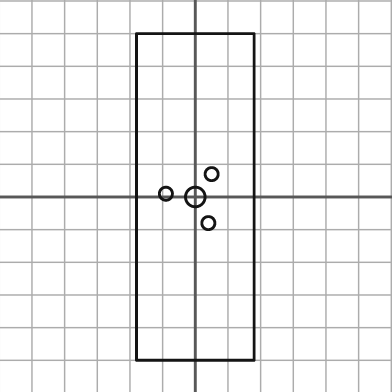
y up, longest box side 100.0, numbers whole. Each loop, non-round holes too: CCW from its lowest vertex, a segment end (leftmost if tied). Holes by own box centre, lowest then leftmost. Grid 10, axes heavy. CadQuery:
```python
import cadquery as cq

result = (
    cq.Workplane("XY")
    .moveTo(-18.0, -50.0)
    .lineTo(18.0, -50.0)
    .lineTo(18.0, 50.0)
    .lineTo(-18.0, 50.0)
    .close()
    .moveTo(4.0, -8.0)
    .circle(2.0)
    .moveTo(0.0, 0.0)
    .circle(3.0)
    .moveTo(-9.0, 1.0)
    .circle(2.0)
    .moveTo(5.0, 7.0)
    .circle(2.0)
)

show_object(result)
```